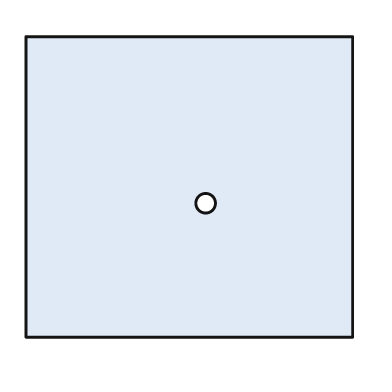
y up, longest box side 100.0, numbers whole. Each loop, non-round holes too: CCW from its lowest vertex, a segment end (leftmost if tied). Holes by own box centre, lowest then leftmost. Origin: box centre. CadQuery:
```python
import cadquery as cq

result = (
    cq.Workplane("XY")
    .moveTo(-50.0, -46.0)
    .lineTo(50.0, -46.0)
    .lineTo(50.0, 46.0)
    .lineTo(-50.0, 46.0)
    .close()
    .moveTo(5.0, -5.0)
    .circle(3.0)
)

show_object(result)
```